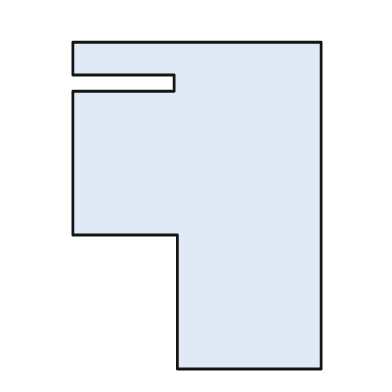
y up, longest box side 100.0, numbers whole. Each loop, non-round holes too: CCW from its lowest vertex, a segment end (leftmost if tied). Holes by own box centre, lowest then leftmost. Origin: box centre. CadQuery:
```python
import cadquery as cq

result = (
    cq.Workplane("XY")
    .moveTo(-6.0, -50.0)
    .lineTo(38.0, -50.0)
    .lineTo(38.0, 50.0)
    .lineTo(-38.0, 50.0)
    .lineTo(-38.0, 40.0)
    .lineTo(-7.0, 40.0)
    .lineTo(-7.0, 35.0)
    .lineTo(-38.0, 35.0)
    .lineTo(-38.0, -9.0)
    .lineTo(-6.0, -9.0)
    .close()
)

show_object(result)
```